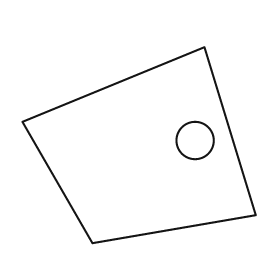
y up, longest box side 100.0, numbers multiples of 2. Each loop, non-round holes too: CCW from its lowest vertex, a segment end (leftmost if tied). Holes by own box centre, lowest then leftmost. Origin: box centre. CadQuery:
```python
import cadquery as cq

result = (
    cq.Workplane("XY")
    .moveTo(-20.0, -42.0)
    .lineTo(50.0, -30.0)
    .lineTo(28.0, 42.0)
    .lineTo(-50.0, 10.0)
    .close()
    .moveTo(24.0, 2.0)
    .circle(8.0)
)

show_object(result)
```